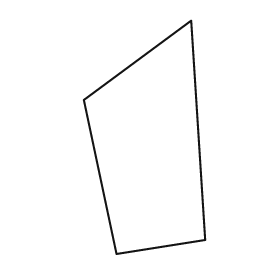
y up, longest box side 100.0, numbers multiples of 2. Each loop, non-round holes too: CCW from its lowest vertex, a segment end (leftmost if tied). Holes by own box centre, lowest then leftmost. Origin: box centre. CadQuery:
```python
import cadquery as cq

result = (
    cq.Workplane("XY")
    .moveTo(-12.0, -50.0)
    .lineTo(26.0, -44.0)
    .lineTo(20.0, 50.0)
    .lineTo(-26.0, 16.0)
    .close()
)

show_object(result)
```